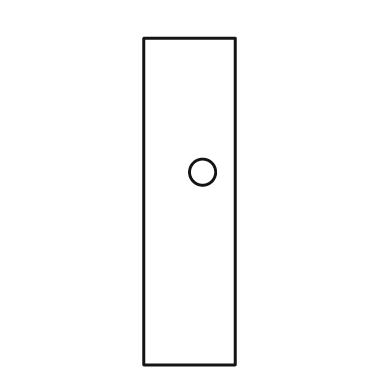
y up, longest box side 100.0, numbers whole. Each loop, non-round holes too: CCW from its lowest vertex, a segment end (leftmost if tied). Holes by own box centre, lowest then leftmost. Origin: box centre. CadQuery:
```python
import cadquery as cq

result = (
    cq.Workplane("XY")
    .moveTo(-14.0, -50.0)
    .lineTo(14.0, -50.0)
    .lineTo(14.0, 50.0)
    .lineTo(-14.0, 50.0)
    .close()
    .moveTo(4.0, 9.0)
    .circle(4.0)
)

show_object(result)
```